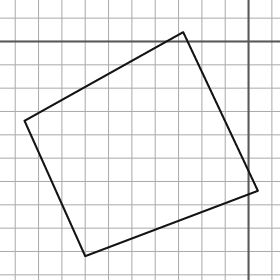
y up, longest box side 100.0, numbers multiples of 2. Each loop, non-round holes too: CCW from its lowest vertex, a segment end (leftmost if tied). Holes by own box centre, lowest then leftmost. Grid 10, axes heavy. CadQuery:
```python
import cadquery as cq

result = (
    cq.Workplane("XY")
    .moveTo(-70.0, -92.0)
    .lineTo(4.0, -64.0)
    .lineTo(-28.0, 4.0)
    .lineTo(-96.0, -34.0)
    .close()
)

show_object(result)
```